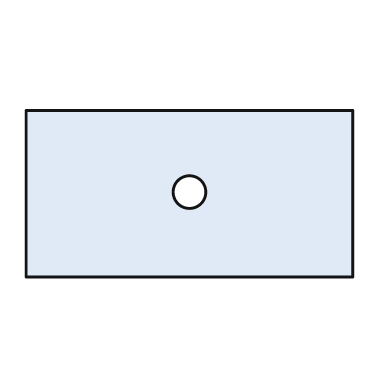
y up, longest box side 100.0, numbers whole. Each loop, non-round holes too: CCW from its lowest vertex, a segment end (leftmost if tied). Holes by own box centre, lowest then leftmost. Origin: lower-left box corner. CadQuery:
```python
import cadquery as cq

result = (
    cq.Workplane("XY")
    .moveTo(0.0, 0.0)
    .lineTo(100.0, 0.0)
    .lineTo(100.0, 51.0)
    .lineTo(0.0, 51.0)
    .close()
    .moveTo(50.0, 26.0)
    .circle(5.0)
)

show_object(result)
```